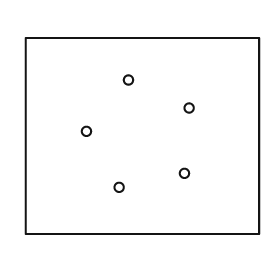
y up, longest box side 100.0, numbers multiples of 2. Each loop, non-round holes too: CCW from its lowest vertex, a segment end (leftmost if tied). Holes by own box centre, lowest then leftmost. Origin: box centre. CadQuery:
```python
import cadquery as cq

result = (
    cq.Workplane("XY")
    .moveTo(-50.0, -42.0)
    .lineTo(50.0, -42.0)
    .lineTo(50.0, 42.0)
    .lineTo(-50.0, 42.0)
    .close()
    .moveTo(-10.0, -22.0)
    .circle(2.0)
    .moveTo(18.0, -16.0)
    .circle(2.0)
    .moveTo(-24.0, 2.0)
    .circle(2.0)
    .moveTo(20.0, 12.0)
    .circle(2.0)
    .moveTo(-6.0, 24.0)
    .circle(2.0)
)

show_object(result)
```